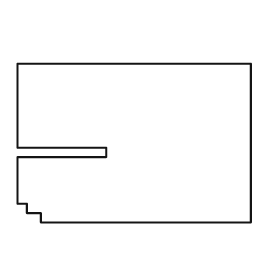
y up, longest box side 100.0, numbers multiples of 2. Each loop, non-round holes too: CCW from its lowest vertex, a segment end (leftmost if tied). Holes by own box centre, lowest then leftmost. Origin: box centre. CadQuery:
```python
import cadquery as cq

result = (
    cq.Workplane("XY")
    .moveTo(-40.0, -34.0)
    .lineTo(50.0, -34.0)
    .lineTo(50.0, 34.0)
    .lineTo(-50.0, 34.0)
    .lineTo(-50.0, -2.0)
    .lineTo(-12.0, -2.0)
    .lineTo(-12.0, -6.0)
    .lineTo(-50.0, -6.0)
    .lineTo(-50.0, -26.0)
    .lineTo(-46.0, -26.0)
    .lineTo(-46.0, -30.0)
    .lineTo(-40.0, -30.0)
    .close()
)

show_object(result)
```